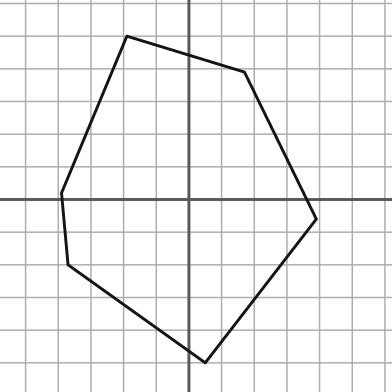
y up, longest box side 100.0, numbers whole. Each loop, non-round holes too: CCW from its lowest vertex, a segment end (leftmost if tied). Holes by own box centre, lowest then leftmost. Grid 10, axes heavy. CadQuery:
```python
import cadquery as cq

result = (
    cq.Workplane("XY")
    .moveTo(5.0, -50.0)
    .lineTo(39.0, -6.0)
    .lineTo(17.0, 39.0)
    .lineTo(-19.0, 50.0)
    .lineTo(-39.0, 2.0)
    .lineTo(-37.0, -20.0)
    .close()
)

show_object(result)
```